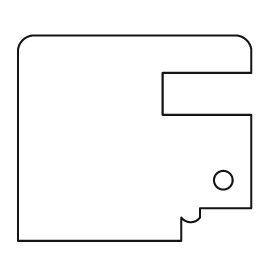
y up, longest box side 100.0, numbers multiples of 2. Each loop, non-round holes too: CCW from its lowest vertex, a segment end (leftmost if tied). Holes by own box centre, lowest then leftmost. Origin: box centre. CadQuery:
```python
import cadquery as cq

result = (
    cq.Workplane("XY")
    .moveTo(-50.0, -44.0)
    .lineTo(20.0, -44.0)
    .lineTo(20.0, -34.0)
    .threePointArc((24.0, -36.0), (28.0, -34.0))
    .lineTo(28.0, -30.0)
    .lineTo(50.0, -30.0)
    .lineTo(50.0, 10.0)
    .lineTo(12.0, 10.0)
    .lineTo(12.0, 28.0)
    .lineTo(50.0, 28.0)
    .lineTo(50.0, 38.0)
    .threePointArc((48.0, 42.0), (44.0, 44.0))
    .lineTo(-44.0, 44.0)
    .threePointArc((-48.0, 42.0), (-50.0, 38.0))
    .close()
    .moveTo(38.0, -18.0)
    .circle(4.0)
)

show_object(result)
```